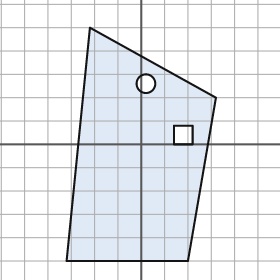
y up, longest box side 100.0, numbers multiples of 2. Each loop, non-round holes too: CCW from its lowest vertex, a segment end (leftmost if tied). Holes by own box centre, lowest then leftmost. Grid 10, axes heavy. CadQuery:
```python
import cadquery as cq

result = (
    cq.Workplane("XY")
    .moveTo(-32.0, -50.0)
    .lineTo(20.0, -50.0)
    .lineTo(32.0, 20.0)
    .lineTo(-22.0, 50.0)
    .close()
    .moveTo(14.0, 0.0)
    .lineTo(22.0, 0.0)
    .lineTo(22.0, 8.0)
    .lineTo(14.0, 8.0)
    .close()
    .moveTo(2.0, 26.0)
    .circle(4.0)
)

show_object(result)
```